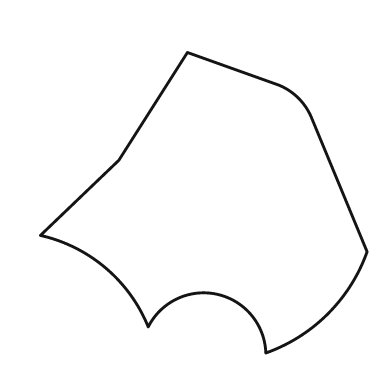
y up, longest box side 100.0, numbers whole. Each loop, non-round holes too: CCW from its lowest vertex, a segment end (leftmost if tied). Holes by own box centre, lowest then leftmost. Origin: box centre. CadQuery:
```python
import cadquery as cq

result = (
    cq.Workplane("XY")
    .moveTo(19.0, -46.0)
    .threePointArc((38.0, -34.0), (50.0, -15.0))
    .lineTo(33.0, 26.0)
    .threePointArc((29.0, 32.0), (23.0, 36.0))
    .lineTo(-5.0, 46.0)
    .lineTo(-26.0, 13.0)
    .lineTo(-50.0, -10.0)
    .threePointArc((-30.0, -20.0), (-17.0, -38.0))
    .threePointArc((4.0, -28.0), (19.0, -46.0))
    .close()
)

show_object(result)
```